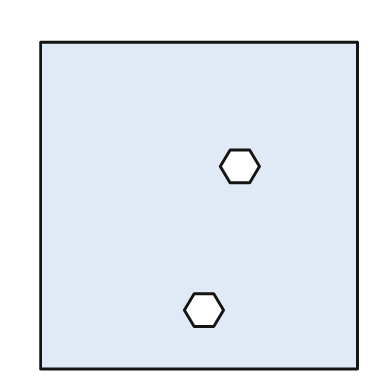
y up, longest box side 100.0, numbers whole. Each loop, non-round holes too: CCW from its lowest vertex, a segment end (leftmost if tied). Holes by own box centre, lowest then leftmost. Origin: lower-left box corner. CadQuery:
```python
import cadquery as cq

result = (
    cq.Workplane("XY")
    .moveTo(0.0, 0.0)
    .lineTo(97.0, 0.0)
    .lineTo(97.0, 100.0)
    .lineTo(0.0, 100.0)
    .close()
    .moveTo(47.0, 13.0)
    .lineTo(53.0, 13.0)
    .lineTo(56.0, 18.0)
    .lineTo(53.0, 23.0)
    .lineTo(47.0, 23.0)
    .lineTo(44.0, 18.0)
    .close()
    .moveTo(58.0, 57.0)
    .lineTo(64.0, 57.0)
    .lineTo(67.0, 62.0)
    .lineTo(64.0, 67.0)
    .lineTo(58.0, 67.0)
    .lineTo(55.0, 62.0)
    .close()
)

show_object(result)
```